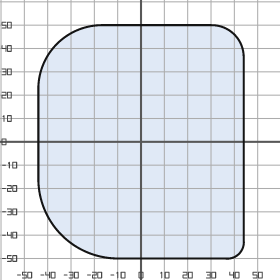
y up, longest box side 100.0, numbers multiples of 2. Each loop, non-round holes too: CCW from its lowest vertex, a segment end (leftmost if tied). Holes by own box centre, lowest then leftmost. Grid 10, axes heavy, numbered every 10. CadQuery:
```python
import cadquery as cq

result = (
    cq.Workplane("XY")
    .moveTo(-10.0, -50.0)
    .lineTo(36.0, -50.0)
    .threePointArc((42.0, -48.0), (44.0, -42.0))
    .lineTo(44.0, 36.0)
    .threePointArc((40.0, 46.0), (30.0, 50.0))
    .lineTo(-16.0, 50.0)
    .threePointArc((-36.0, 42.0), (-44.0, 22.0))
    .lineTo(-44.0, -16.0)
    .threePointArc((-34.0, -40.0), (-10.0, -50.0))
    .close()
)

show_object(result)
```